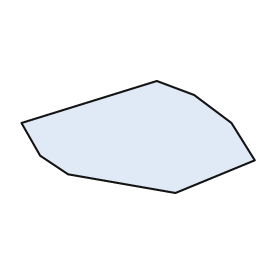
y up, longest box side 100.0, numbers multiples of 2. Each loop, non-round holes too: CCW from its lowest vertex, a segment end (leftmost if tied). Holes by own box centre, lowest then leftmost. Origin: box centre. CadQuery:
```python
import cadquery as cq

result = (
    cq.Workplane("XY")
    .moveTo(16.0, -24.0)
    .lineTo(50.0, -10.0)
    .lineTo(40.0, 6.0)
    .lineTo(24.0, 18.0)
    .lineTo(8.0, 24.0)
    .lineTo(-50.0, 6.0)
    .lineTo(-42.0, -8.0)
    .lineTo(-30.0, -16.0)
    .close()
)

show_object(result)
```